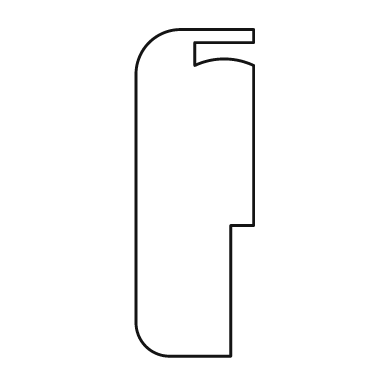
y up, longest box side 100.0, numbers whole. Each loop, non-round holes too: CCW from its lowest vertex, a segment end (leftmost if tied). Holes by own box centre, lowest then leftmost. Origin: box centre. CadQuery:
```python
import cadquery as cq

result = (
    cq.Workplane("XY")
    .moveTo(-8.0, -50.0)
    .lineTo(11.0, -50.0)
    .lineTo(11.0, -10.0)
    .lineTo(18.0, -10.0)
    .lineTo(18.0, 39.0)
    .threePointArc((9.0, 41.0), (0.0, 39.0))
    .lineTo(0.0, 46.0)
    .lineTo(18.0, 46.0)
    .lineTo(18.0, 50.0)
    .lineTo(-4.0, 50.0)
    .threePointArc((-14.0, 46.0), (-18.0, 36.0))
    .lineTo(-18.0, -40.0)
    .threePointArc((-15.0, -47.0), (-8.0, -50.0))
    .close()
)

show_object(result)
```